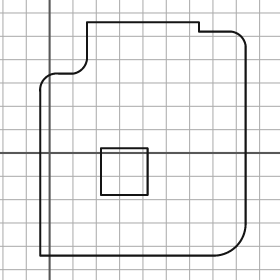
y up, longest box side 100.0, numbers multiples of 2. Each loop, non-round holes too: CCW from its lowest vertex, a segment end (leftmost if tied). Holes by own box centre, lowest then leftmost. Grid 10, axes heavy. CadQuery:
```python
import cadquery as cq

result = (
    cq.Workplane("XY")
    .moveTo(-4.0, -44.0)
    .lineTo(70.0, -44.0)
    .threePointArc((80.0, -40.0), (84.0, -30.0))
    .lineTo(84.0, 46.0)
    .threePointArc((82.0, 50.0), (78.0, 52.0))
    .lineTo(64.0, 52.0)
    .lineTo(64.0, 56.0)
    .lineTo(16.0, 56.0)
    .lineTo(16.0, 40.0)
    .threePointArc((14.0, 36.0), (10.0, 34.0))
    .lineTo(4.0, 34.0)
    .threePointArc((-2.0, 32.0), (-4.0, 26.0))
    .close()
    .moveTo(22.0, -18.0)
    .lineTo(42.0, -18.0)
    .lineTo(42.0, 2.0)
    .lineTo(22.0, 2.0)
    .close()
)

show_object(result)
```